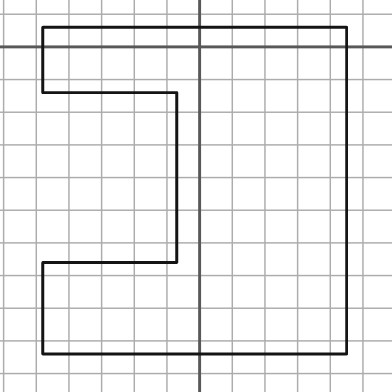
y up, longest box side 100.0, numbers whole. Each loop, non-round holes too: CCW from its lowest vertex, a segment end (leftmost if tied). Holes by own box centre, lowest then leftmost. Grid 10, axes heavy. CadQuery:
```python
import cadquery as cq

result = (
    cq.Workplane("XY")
    .moveTo(-48.0, -94.0)
    .lineTo(45.0, -94.0)
    .lineTo(45.0, 6.0)
    .lineTo(-48.0, 6.0)
    .lineTo(-48.0, -14.0)
    .lineTo(-7.0, -14.0)
    .lineTo(-7.0, -66.0)
    .lineTo(-48.0, -66.0)
    .close()
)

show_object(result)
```